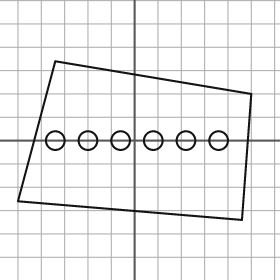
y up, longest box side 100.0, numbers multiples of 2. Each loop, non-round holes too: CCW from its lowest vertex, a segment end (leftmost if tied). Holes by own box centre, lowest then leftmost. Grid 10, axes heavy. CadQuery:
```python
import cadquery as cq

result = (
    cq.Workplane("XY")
    .moveTo(46.0, -34.0)
    .lineTo(50.0, 20.0)
    .lineTo(-34.0, 34.0)
    .lineTo(-50.0, -26.0)
    .close()
    .moveTo(-34.0, 0.0)
    .circle(4.0)
    .moveTo(-20.0, 0.0)
    .circle(4.0)
    .moveTo(-6.0, 0.0)
    .circle(4.0)
    .moveTo(8.0, 0.0)
    .circle(4.0)
    .moveTo(22.0, 0.0)
    .circle(4.0)
    .moveTo(36.0, 0.0)
    .circle(4.0)
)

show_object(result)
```